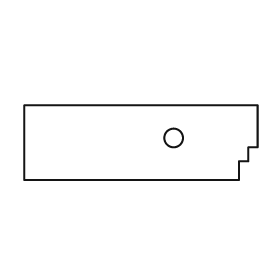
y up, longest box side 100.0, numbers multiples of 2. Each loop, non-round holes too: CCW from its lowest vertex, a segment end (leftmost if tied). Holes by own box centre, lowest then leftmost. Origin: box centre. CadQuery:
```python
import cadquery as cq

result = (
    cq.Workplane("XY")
    .moveTo(-50.0, -16.0)
    .lineTo(42.0, -16.0)
    .lineTo(42.0, -8.0)
    .lineTo(46.0, -8.0)
    .lineTo(46.0, -2.0)
    .lineTo(50.0, -2.0)
    .lineTo(50.0, 16.0)
    .lineTo(-50.0, 16.0)
    .close()
    .moveTo(14.0, 2.0)
    .circle(4.0)
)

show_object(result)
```